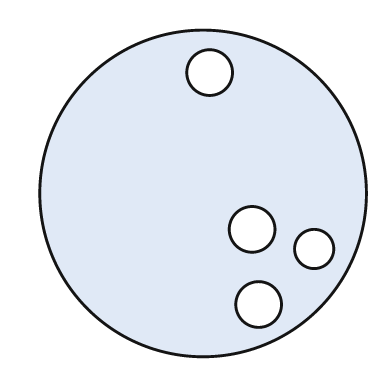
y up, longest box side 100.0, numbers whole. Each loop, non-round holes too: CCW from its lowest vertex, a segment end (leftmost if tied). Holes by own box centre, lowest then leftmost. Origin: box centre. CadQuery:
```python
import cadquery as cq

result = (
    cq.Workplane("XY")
    .moveTo(0.0, 0.0)
    .circle(50.0)
    .moveTo(17.0, -34.0)
    .circle(7.0)
    .moveTo(34.0, -17.0)
    .circle(6.0)
    .moveTo(15.0, -11.0)
    .circle(7.0)
    .moveTo(2.0, 37.0)
    .circle(7.0)
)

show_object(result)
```